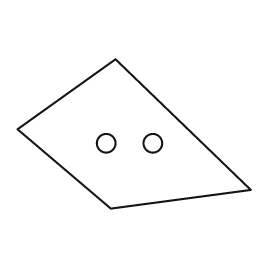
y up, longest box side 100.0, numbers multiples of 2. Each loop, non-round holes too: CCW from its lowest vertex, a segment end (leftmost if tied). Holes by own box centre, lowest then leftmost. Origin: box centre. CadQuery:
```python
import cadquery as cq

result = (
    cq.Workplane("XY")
    .moveTo(-10.0, -32.0)
    .lineTo(50.0, -24.0)
    .lineTo(-8.0, 32.0)
    .lineTo(-50.0, 2.0)
    .close()
    .moveTo(-12.0, -4.0)
    .circle(4.0)
    .moveTo(8.0, -4.0)
    .circle(4.0)
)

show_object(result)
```